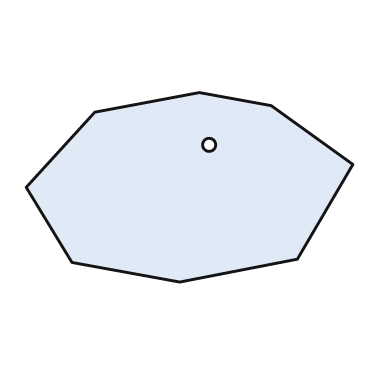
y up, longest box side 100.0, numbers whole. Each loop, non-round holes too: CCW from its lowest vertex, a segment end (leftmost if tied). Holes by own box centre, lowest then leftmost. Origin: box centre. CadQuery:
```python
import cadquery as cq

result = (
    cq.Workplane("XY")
    .moveTo(-3.0, -29.0)
    .lineTo(33.0, -22.0)
    .lineTo(50.0, 7.0)
    .lineTo(25.0, 25.0)
    .lineTo(3.0, 29.0)
    .lineTo(-29.0, 23.0)
    .lineTo(-50.0, 0.0)
    .lineTo(-36.0, -23.0)
    .close()
    .moveTo(6.0, 13.0)
    .circle(2.0)
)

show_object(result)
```